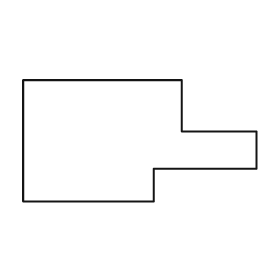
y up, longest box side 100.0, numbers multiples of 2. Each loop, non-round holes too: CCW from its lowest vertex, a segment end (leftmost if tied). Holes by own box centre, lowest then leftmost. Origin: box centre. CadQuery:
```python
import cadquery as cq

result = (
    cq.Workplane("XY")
    .moveTo(-50.0, -26.0)
    .lineTo(6.0, -26.0)
    .lineTo(6.0, -12.0)
    .lineTo(50.0, -12.0)
    .lineTo(50.0, 4.0)
    .lineTo(18.0, 4.0)
    .lineTo(18.0, 26.0)
    .lineTo(-50.0, 26.0)
    .close()
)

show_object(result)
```